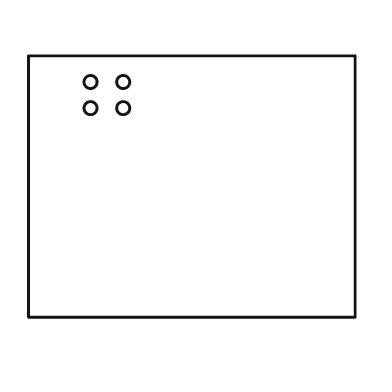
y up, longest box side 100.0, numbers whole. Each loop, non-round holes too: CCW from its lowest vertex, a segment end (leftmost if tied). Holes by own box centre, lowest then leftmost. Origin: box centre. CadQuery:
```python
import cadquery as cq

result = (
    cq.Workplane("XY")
    .moveTo(-50.0, -40.0)
    .lineTo(50.0, -40.0)
    .lineTo(50.0, 40.0)
    .lineTo(-50.0, 40.0)
    .close()
    .moveTo(-31.0, 24.0)
    .circle(2.0)
    .moveTo(-21.0, 24.0)
    .circle(2.0)
    .moveTo(-31.0, 32.0)
    .circle(2.0)
    .moveTo(-21.0, 32.0)
    .circle(2.0)
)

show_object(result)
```